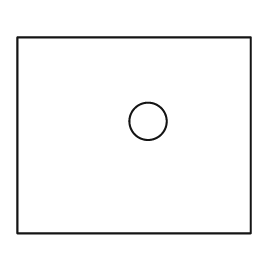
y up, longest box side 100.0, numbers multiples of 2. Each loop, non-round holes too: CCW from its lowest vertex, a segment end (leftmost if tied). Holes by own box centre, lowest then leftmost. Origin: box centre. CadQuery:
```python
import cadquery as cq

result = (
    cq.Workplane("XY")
    .moveTo(-50.0, -42.0)
    .lineTo(50.0, -42.0)
    .lineTo(50.0, 42.0)
    .lineTo(-50.0, 42.0)
    .close()
    .moveTo(6.0, 6.0)
    .circle(8.0)
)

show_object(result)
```